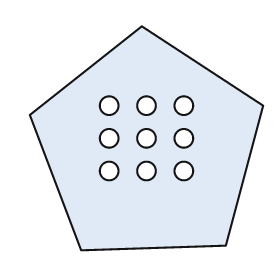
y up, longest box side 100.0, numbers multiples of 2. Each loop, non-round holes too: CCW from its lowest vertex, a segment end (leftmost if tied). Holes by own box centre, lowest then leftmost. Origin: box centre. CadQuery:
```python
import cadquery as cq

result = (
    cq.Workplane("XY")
    .moveTo(-28.0, -48.0)
    .lineTo(34.0, -46.0)
    .lineTo(50.0, 14.0)
    .lineTo(-2.0, 48.0)
    .lineTo(-50.0, 10.0)
    .close()
    .moveTo(-16.0, -14.0)
    .circle(4.0)
    .moveTo(0.0, -14.0)
    .circle(4.0)
    .moveTo(16.0, -14.0)
    .circle(4.0)
    .moveTo(-16.0, 0.0)
    .circle(4.0)
    .moveTo(0.0, 0.0)
    .circle(4.0)
    .moveTo(16.0, 0.0)
    .circle(4.0)
    .moveTo(-16.0, 14.0)
    .circle(4.0)
    .moveTo(0.0, 14.0)
    .circle(4.0)
    .moveTo(16.0, 14.0)
    .circle(4.0)
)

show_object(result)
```